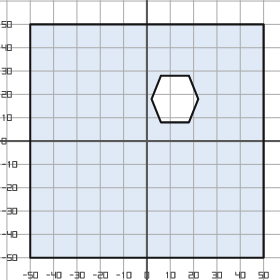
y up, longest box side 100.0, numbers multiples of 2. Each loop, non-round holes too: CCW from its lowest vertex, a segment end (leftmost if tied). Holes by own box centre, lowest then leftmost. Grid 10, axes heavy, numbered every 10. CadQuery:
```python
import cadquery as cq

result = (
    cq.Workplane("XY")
    .moveTo(-50.0, -50.0)
    .lineTo(50.0, -50.0)
    .lineTo(50.0, 50.0)
    .lineTo(-50.0, 50.0)
    .close()
    .moveTo(6.0, 8.0)
    .lineTo(18.0, 8.0)
    .lineTo(22.0, 18.0)
    .lineTo(18.0, 28.0)
    .lineTo(6.0, 28.0)
    .lineTo(2.0, 18.0)
    .close()
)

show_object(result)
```